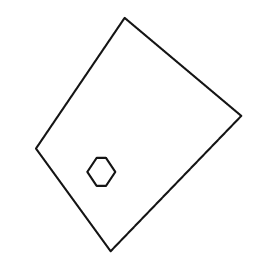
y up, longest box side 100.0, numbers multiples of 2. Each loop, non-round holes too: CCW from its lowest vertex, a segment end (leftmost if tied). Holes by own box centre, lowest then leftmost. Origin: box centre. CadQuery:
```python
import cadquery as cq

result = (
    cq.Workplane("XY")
    .moveTo(-12.0, -50.0)
    .lineTo(44.0, 8.0)
    .lineTo(-6.0, 50.0)
    .lineTo(-44.0, -6.0)
    .close()
    .moveTo(-18.0, -22.0)
    .lineTo(-14.0, -22.0)
    .lineTo(-10.0, -16.0)
    .lineTo(-14.0, -10.0)
    .lineTo(-18.0, -10.0)
    .lineTo(-22.0, -16.0)
    .close()
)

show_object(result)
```